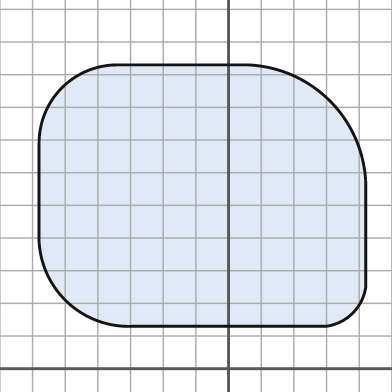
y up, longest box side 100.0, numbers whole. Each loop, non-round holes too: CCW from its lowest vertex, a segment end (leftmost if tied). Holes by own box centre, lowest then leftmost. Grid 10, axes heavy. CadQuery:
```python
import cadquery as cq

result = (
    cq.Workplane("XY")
    .moveTo(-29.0, 13.0)
    .lineTo(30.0, 13.0)
    .threePointArc((38.0, 17.0), (42.0, 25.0))
    .lineTo(42.0, 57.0)
    .threePointArc((31.0, 82.0), (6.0, 93.0))
    .lineTo(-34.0, 93.0)
    .threePointArc((-51.0, 86.0), (-58.0, 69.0))
    .lineTo(-58.0, 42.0)
    .threePointArc((-50.0, 21.0), (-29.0, 13.0))
    .close()
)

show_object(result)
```